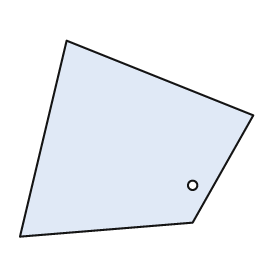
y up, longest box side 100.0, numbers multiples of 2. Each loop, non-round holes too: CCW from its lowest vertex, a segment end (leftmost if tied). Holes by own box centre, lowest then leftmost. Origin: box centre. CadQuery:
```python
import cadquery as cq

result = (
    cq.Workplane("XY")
    .moveTo(-50.0, -42.0)
    .lineTo(24.0, -36.0)
    .lineTo(50.0, 10.0)
    .lineTo(-30.0, 42.0)
    .close()
    .moveTo(24.0, -20.0)
    .circle(2.0)
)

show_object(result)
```